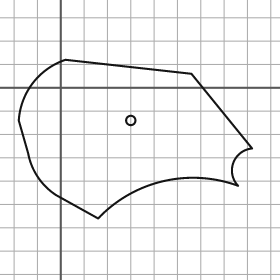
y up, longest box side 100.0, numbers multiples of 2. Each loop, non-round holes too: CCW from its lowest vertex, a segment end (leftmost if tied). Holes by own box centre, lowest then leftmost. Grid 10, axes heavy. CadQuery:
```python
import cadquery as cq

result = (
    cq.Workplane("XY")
    .moveTo(16.0, -56.0)
    .threePointArc((44.0, -40.0), (76.0, -42.0))
    .threePointArc((74.0, -32.0), (82.0, -26.0))
    .lineTo(56.0, 6.0)
    .lineTo(2.0, 12.0)
    .threePointArc((-12.0, 2.0), (-18.0, -14.0))
    .lineTo(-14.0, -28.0)
    .threePointArc((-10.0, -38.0), (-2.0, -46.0))
    .close()
    .moveTo(30.0, -14.0)
    .circle(2.0)
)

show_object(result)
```